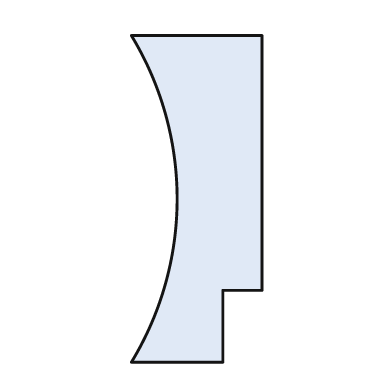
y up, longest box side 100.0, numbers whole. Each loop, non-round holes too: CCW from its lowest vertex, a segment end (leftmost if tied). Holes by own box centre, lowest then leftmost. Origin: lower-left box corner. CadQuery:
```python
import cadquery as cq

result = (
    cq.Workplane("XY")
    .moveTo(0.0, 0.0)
    .lineTo(28.0, 0.0)
    .lineTo(28.0, 22.0)
    .lineTo(40.0, 22.0)
    .lineTo(40.0, 100.0)
    .lineTo(0.0, 100.0)
    .threePointArc((14.0, 50.0), (0.0, 0.0))
    .close()
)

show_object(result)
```